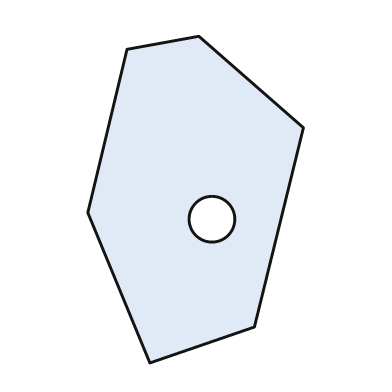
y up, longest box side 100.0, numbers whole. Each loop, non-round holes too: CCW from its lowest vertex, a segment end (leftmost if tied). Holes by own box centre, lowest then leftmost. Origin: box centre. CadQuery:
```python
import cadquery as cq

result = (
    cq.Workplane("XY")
    .moveTo(-14.0, -50.0)
    .lineTo(18.0, -39.0)
    .lineTo(33.0, 22.0)
    .lineTo(1.0, 50.0)
    .lineTo(-21.0, 46.0)
    .lineTo(-33.0, -4.0)
    .close()
    .moveTo(5.0, -6.0)
    .circle(7.0)
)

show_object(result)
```